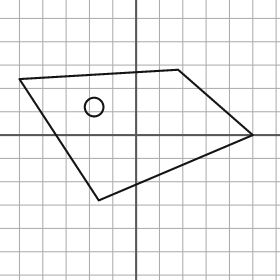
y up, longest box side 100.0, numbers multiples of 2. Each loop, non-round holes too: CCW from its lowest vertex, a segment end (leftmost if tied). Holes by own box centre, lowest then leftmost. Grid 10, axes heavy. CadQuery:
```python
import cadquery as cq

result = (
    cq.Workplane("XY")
    .moveTo(-16.0, -28.0)
    .lineTo(50.0, 0.0)
    .lineTo(18.0, 28.0)
    .lineTo(-50.0, 24.0)
    .close()
    .moveTo(-18.0, 12.0)
    .circle(4.0)
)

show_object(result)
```